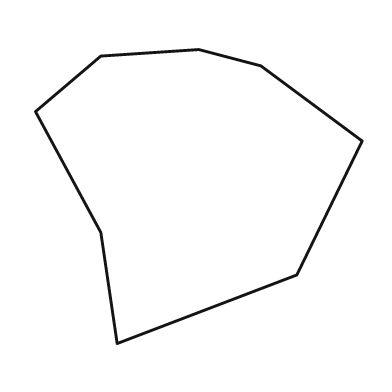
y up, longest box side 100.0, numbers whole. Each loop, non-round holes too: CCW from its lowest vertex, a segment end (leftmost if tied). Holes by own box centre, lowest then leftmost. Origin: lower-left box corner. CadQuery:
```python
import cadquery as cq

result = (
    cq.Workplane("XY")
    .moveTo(25.0, 0.0)
    .lineTo(80.0, 21.0)
    .lineTo(100.0, 62.0)
    .lineTo(69.0, 85.0)
    .lineTo(50.0, 90.0)
    .lineTo(20.0, 88.0)
    .lineTo(0.0, 71.0)
    .lineTo(20.0, 34.0)
    .close()
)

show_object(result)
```